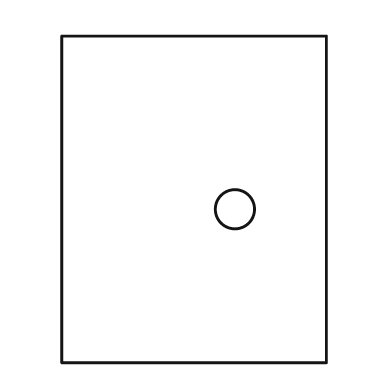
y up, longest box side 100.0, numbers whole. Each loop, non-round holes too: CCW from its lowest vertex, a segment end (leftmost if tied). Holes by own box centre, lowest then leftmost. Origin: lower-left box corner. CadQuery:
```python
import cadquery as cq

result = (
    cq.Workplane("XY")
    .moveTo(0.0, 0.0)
    .lineTo(81.0, 0.0)
    .lineTo(81.0, 100.0)
    .lineTo(0.0, 100.0)
    .close()
    .moveTo(53.0, 47.0)
    .circle(6.0)
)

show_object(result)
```